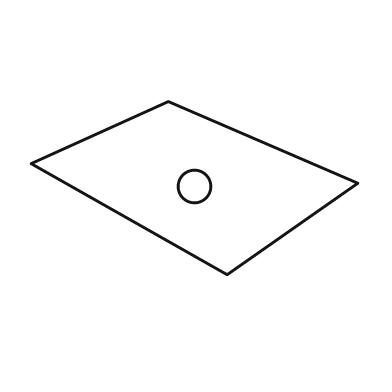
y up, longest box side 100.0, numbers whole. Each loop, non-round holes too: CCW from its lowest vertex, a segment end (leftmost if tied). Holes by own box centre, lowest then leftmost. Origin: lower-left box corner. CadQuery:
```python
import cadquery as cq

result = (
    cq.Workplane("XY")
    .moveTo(60.0, 0.0)
    .lineTo(100.0, 28.0)
    .lineTo(42.0, 53.0)
    .lineTo(0.0, 34.0)
    .close()
    .moveTo(50.0, 27.0)
    .circle(5.0)
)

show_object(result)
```